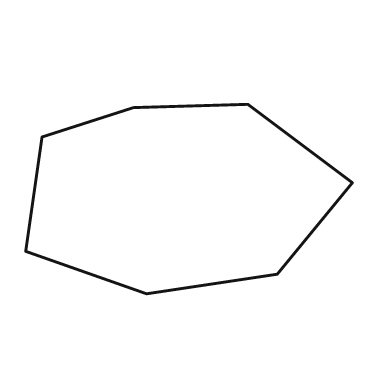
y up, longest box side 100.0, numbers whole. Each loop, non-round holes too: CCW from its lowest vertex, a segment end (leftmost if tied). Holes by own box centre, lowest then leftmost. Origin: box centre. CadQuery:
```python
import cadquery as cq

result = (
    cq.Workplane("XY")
    .moveTo(-13.0, -29.0)
    .lineTo(27.0, -23.0)
    .lineTo(50.0, 5.0)
    .lineTo(18.0, 29.0)
    .lineTo(-17.0, 28.0)
    .lineTo(-45.0, 19.0)
    .lineTo(-50.0, -16.0)
    .close()
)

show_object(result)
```